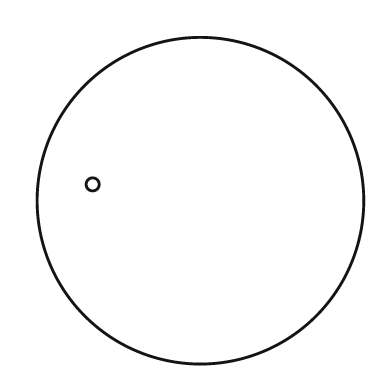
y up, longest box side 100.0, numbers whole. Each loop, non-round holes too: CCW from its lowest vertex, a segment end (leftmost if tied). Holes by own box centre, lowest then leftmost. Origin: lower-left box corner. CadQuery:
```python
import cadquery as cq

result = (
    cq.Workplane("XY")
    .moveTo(50.0, 50.0)
    .circle(50.0)
    .moveTo(17.0, 55.0)
    .circle(2.0)
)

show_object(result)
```